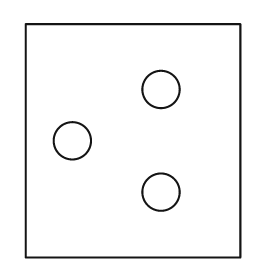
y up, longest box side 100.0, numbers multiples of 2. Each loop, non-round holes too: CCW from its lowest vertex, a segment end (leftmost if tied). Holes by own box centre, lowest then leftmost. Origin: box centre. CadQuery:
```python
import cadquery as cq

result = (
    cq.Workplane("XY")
    .moveTo(-46.0, -50.0)
    .lineTo(46.0, -50.0)
    .lineTo(46.0, 50.0)
    .lineTo(-46.0, 50.0)
    .close()
    .moveTo(12.0, -22.0)
    .circle(8.0)
    .moveTo(-26.0, 0.0)
    .circle(8.0)
    .moveTo(12.0, 22.0)
    .circle(8.0)
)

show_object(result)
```